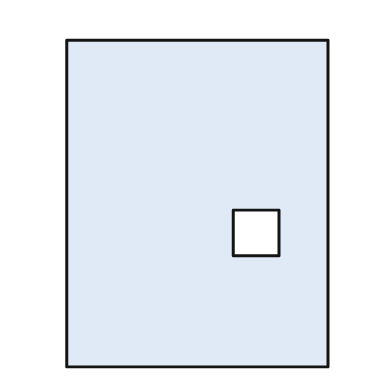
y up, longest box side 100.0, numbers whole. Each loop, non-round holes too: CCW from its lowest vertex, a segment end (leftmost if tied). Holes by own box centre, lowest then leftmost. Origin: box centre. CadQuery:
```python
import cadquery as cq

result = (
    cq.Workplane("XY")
    .moveTo(-40.0, -50.0)
    .lineTo(40.0, -50.0)
    .lineTo(40.0, 50.0)
    .lineTo(-40.0, 50.0)
    .close()
    .moveTo(11.0, -16.0)
    .lineTo(25.0, -16.0)
    .lineTo(25.0, -2.0)
    .lineTo(11.0, -2.0)
    .close()
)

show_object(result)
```